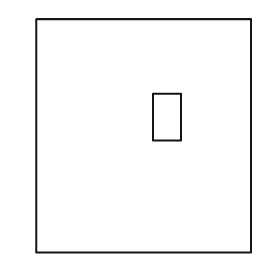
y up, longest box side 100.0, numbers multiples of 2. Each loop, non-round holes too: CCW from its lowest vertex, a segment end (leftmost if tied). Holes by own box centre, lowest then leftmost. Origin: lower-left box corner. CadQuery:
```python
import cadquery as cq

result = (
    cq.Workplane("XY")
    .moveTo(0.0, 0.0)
    .lineTo(92.0, 0.0)
    .lineTo(92.0, 100.0)
    .lineTo(0.0, 100.0)
    .close()
    .moveTo(50.0, 48.0)
    .lineTo(62.0, 48.0)
    .lineTo(62.0, 68.0)
    .lineTo(50.0, 68.0)
    .close()
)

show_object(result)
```